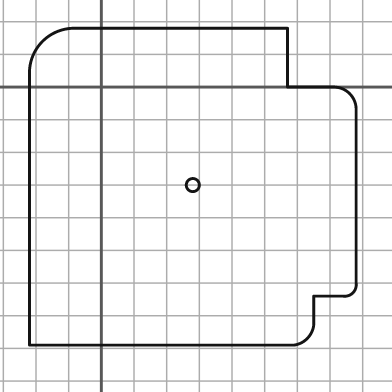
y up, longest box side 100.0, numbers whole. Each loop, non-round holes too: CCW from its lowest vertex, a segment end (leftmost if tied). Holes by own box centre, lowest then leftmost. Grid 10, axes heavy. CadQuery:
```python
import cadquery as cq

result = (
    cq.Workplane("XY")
    .moveTo(-22.0, -79.0)
    .lineTo(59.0, -79.0)
    .threePointArc((63.0, -77.0), (65.0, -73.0))
    .lineTo(65.0, -64.0)
    .lineTo(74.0, -64.0)
    .threePointArc((77.0, -63.0), (78.0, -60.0))
    .lineTo(78.0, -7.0)
    .threePointArc((76.0, -2.0), (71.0, 0.0))
    .lineTo(57.0, 0.0)
    .lineTo(57.0, 18.0)
    .lineTo(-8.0, 18.0)
    .threePointArc((-18.0, 14.0), (-22.0, 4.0))
    .close()
    .moveTo(28.0, -30.0)
    .circle(2.0)
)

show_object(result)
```